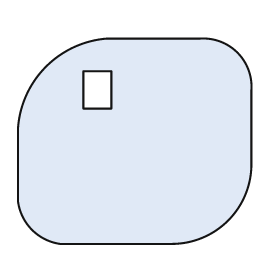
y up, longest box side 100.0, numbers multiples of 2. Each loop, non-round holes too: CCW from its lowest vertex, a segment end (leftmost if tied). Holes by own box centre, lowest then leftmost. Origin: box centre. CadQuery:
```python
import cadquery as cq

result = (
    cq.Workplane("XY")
    .moveTo(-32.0, -44.0)
    .lineTo(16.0, -44.0)
    .threePointArc((40.0, -34.0), (50.0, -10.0))
    .lineTo(50.0, 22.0)
    .threePointArc((44.0, 38.0), (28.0, 44.0))
    .lineTo(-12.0, 44.0)
    .threePointArc((-38.0, 32.0), (-50.0, 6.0))
    .lineTo(-50.0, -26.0)
    .threePointArc((-44.0, -38.0), (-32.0, -44.0))
    .close()
    .moveTo(-22.0, 14.0)
    .lineTo(-10.0, 14.0)
    .lineTo(-10.0, 30.0)
    .lineTo(-22.0, 30.0)
    .close()
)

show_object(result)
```